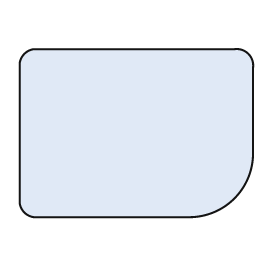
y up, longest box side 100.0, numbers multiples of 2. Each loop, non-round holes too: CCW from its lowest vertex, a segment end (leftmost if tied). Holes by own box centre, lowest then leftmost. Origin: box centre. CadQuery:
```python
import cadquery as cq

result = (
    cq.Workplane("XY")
    .moveTo(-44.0, -36.0)
    .lineTo(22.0, -36.0)
    .threePointArc((42.0, -28.0), (50.0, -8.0))
    .lineTo(50.0, 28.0)
    .threePointArc((48.0, 34.0), (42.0, 36.0))
    .lineTo(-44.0, 36.0)
    .threePointArc((-48.0, 34.0), (-50.0, 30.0))
    .lineTo(-50.0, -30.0)
    .threePointArc((-48.0, -34.0), (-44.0, -36.0))
    .close()
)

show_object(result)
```